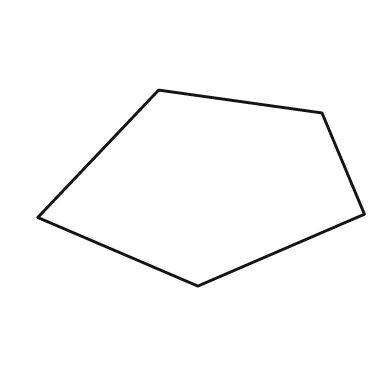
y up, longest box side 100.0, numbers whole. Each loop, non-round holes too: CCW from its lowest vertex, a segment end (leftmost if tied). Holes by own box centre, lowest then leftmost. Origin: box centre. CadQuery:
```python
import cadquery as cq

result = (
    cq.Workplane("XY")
    .moveTo(-1.0, -30.0)
    .lineTo(50.0, -8.0)
    .lineTo(37.0, 23.0)
    .lineTo(-13.0, 30.0)
    .lineTo(-50.0, -9.0)
    .close()
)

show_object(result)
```